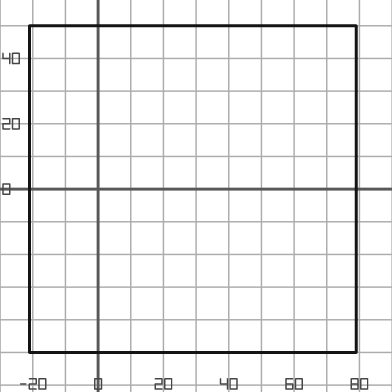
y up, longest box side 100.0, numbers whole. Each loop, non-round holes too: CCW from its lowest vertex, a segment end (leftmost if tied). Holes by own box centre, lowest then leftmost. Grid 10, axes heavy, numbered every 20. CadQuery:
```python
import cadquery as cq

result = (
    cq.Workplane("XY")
    .moveTo(-21.0, -50.0)
    .lineTo(79.0, -50.0)
    .lineTo(79.0, 50.0)
    .lineTo(-21.0, 50.0)
    .close()
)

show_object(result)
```